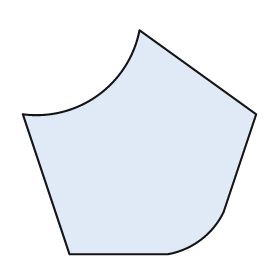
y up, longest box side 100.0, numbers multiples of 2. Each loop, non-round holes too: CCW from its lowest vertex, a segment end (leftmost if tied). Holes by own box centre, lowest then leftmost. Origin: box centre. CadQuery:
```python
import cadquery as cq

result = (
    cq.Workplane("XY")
    .moveTo(-30.0, -48.0)
    .lineTo(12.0, -48.0)
    .threePointArc((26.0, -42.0), (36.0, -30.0))
    .lineTo(50.0, 12.0)
    .lineTo(0.0, 48.0)
    .threePointArc((-18.0, 20.0), (-50.0, 12.0))
    .close()
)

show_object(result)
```